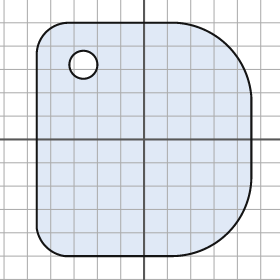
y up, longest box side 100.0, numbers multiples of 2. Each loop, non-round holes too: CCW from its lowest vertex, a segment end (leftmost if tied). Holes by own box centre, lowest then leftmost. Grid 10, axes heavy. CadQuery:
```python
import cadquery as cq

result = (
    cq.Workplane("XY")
    .moveTo(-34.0, -50.0)
    .lineTo(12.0, -50.0)
    .threePointArc((36.0, -40.0), (46.0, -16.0))
    .lineTo(46.0, 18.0)
    .threePointArc((36.0, 40.0), (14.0, 50.0))
    .lineTo(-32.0, 50.0)
    .threePointArc((-42.0, 46.0), (-46.0, 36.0))
    .lineTo(-46.0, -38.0)
    .threePointArc((-42.0, -46.0), (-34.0, -50.0))
    .close()
    .moveTo(-26.0, 32.0)
    .circle(6.0)
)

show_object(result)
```